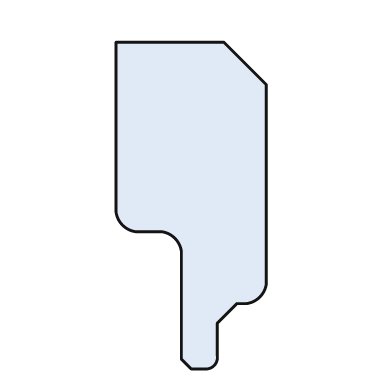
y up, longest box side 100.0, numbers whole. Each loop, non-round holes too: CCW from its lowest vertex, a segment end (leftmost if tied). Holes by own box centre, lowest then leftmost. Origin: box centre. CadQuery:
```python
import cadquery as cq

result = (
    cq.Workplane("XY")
    .moveTo(0.0, -50.0)
    .lineTo(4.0, -50.0)
    .threePointArc((7.0, -49.0), (8.0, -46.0))
    .lineTo(8.0, -36.0)
    .lineTo(14.0, -30.0)
    .lineTo(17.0, -30.0)
    .threePointArc((21.0, -28.0), (23.0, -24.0))
    .lineTo(23.0, 37.0)
    .lineTo(10.0, 50.0)
    .lineTo(-23.0, 50.0)
    .lineTo(-23.0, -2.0)
    .threePointArc((-21.0, -6.0), (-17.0, -8.0))
    .lineTo(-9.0, -8.0)
    .threePointArc((-5.0, -10.0), (-3.0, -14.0))
    .lineTo(-3.0, -47.0)
    .close()
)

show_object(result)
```